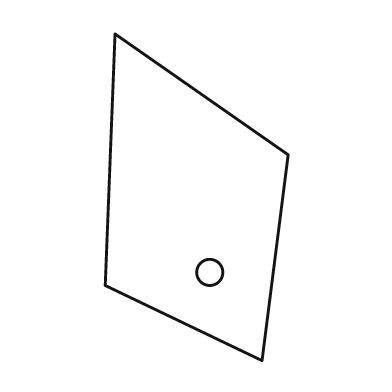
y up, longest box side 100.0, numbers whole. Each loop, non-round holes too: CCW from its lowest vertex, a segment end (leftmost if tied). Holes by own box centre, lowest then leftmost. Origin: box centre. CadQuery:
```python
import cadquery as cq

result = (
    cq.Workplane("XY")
    .moveTo(20.0, -50.0)
    .lineTo(28.0, 13.0)
    .lineTo(-25.0, 50.0)
    .lineTo(-28.0, -27.0)
    .close()
    .moveTo(4.0, -23.0)
    .circle(4.0)
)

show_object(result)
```